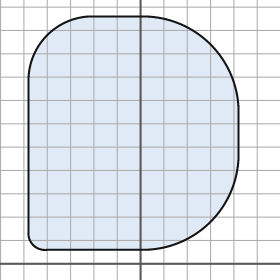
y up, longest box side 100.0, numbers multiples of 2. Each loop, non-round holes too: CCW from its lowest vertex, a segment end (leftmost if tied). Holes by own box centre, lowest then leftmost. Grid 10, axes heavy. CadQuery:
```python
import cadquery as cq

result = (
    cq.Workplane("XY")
    .moveTo(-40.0, 6.0)
    .lineTo(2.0, 6.0)
    .threePointArc((30.0, 18.0), (42.0, 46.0))
    .lineTo(42.0, 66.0)
    .threePointArc((30.0, 94.0), (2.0, 106.0))
    .lineTo(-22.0, 106.0)
    .threePointArc((-40.0, 98.0), (-48.0, 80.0))
    .lineTo(-48.0, 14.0)
    .threePointArc((-46.0, 8.0), (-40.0, 6.0))
    .close()
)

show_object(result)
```